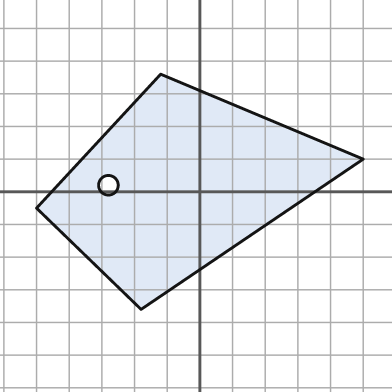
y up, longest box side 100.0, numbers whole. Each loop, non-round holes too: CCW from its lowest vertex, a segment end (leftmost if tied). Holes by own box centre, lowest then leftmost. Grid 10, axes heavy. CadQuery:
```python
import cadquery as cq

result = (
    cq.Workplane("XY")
    .moveTo(-18.0, -36.0)
    .lineTo(50.0, 10.0)
    .lineTo(-12.0, 36.0)
    .lineTo(-50.0, -5.0)
    .close()
    .moveTo(-28.0, 2.0)
    .circle(3.0)
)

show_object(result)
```